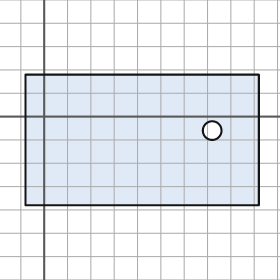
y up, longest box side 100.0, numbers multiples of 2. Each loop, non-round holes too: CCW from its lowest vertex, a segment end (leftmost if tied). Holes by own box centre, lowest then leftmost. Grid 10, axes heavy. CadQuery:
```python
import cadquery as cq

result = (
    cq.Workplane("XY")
    .moveTo(-8.0, -38.0)
    .lineTo(92.0, -38.0)
    .lineTo(92.0, 18.0)
    .lineTo(-8.0, 18.0)
    .close()
    .moveTo(72.0, -6.0)
    .circle(4.0)
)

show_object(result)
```